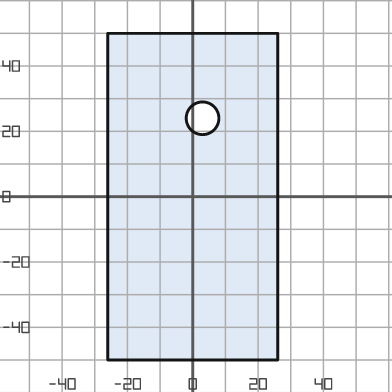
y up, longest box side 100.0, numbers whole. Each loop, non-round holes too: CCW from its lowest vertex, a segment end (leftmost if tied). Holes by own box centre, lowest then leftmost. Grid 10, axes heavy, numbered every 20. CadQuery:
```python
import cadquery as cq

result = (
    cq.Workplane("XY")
    .moveTo(-26.0, -50.0)
    .lineTo(26.0, -50.0)
    .lineTo(26.0, 50.0)
    .lineTo(-26.0, 50.0)
    .close()
    .moveTo(3.0, 24.0)
    .circle(5.0)
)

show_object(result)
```